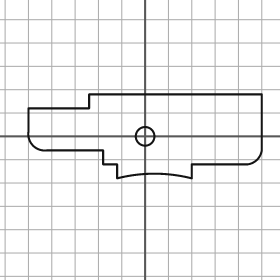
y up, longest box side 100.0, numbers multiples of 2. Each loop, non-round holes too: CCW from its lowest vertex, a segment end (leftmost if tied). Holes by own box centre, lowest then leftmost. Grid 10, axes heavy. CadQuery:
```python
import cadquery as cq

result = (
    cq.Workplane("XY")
    .moveTo(-12.0, -18.0)
    .threePointArc((4.0, -16.0), (20.0, -18.0))
    .lineTo(20.0, -12.0)
    .lineTo(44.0, -12.0)
    .threePointArc((48.0, -10.0), (50.0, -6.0))
    .lineTo(50.0, 18.0)
    .lineTo(-24.0, 18.0)
    .lineTo(-24.0, 12.0)
    .lineTo(-50.0, 12.0)
    .lineTo(-50.0, 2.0)
    .threePointArc((-48.0, -4.0), (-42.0, -6.0))
    .lineTo(-18.0, -6.0)
    .lineTo(-18.0, -12.0)
    .lineTo(-12.0, -12.0)
    .close()
    .moveTo(0.0, 0.0)
    .circle(4.0)
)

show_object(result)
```